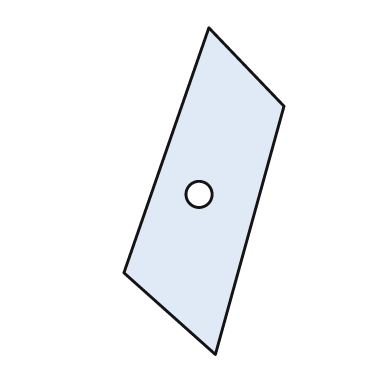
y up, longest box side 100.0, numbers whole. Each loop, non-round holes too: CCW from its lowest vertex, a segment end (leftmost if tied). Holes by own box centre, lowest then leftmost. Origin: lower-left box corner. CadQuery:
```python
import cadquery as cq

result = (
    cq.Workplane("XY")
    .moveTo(28.0, 0.0)
    .lineTo(49.0, 76.0)
    .lineTo(26.0, 100.0)
    .lineTo(0.0, 25.0)
    .close()
    .moveTo(23.0, 49.0)
    .circle(4.0)
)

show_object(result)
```